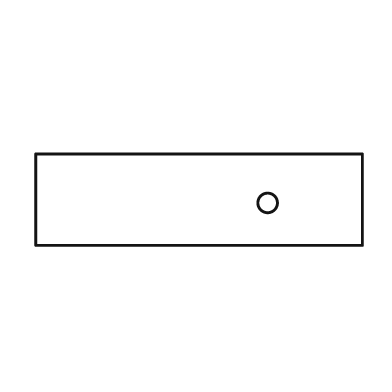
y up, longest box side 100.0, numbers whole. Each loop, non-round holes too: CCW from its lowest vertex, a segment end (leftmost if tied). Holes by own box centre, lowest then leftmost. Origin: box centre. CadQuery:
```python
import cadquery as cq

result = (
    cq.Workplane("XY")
    .moveTo(-50.0, -14.0)
    .lineTo(50.0, -14.0)
    .lineTo(50.0, 14.0)
    .lineTo(-50.0, 14.0)
    .close()
    .moveTo(21.0, -1.0)
    .circle(3.0)
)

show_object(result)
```